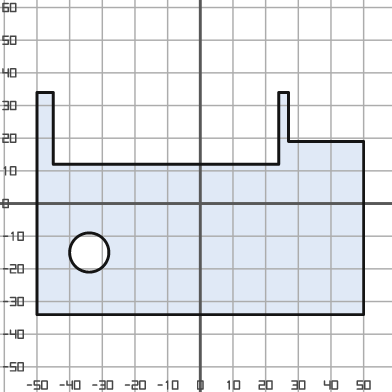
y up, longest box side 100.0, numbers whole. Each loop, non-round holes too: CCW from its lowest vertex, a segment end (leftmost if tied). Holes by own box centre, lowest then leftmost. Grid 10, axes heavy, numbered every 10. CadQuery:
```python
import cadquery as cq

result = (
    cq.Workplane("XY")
    .moveTo(-50.0, -34.0)
    .lineTo(50.0, -34.0)
    .lineTo(50.0, 19.0)
    .lineTo(27.0, 19.0)
    .lineTo(27.0, 34.0)
    .lineTo(24.0, 34.0)
    .lineTo(24.0, 12.0)
    .lineTo(-45.0, 12.0)
    .lineTo(-45.0, 34.0)
    .lineTo(-50.0, 34.0)
    .close()
    .moveTo(-34.0, -15.0)
    .circle(6.0)
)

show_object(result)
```